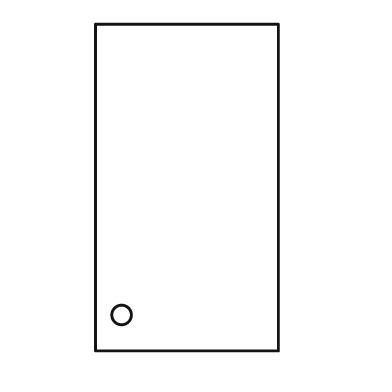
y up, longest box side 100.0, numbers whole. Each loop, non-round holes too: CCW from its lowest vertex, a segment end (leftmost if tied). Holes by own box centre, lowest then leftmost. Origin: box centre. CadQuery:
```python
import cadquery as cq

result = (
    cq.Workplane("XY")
    .moveTo(-28.0, -50.0)
    .lineTo(28.0, -50.0)
    .lineTo(28.0, 50.0)
    .lineTo(-28.0, 50.0)
    .close()
    .moveTo(-20.0, -39.0)
    .circle(3.0)
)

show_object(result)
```